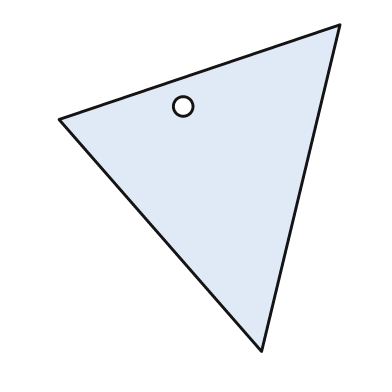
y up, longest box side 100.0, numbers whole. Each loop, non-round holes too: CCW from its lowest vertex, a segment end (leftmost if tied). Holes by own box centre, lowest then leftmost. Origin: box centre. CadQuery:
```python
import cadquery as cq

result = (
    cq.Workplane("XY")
    .moveTo(19.0, -50.0)
    .lineTo(43.0, 50.0)
    .lineTo(-43.0, 21.0)
    .close()
    .moveTo(-5.0, 25.0)
    .circle(3.0)
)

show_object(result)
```